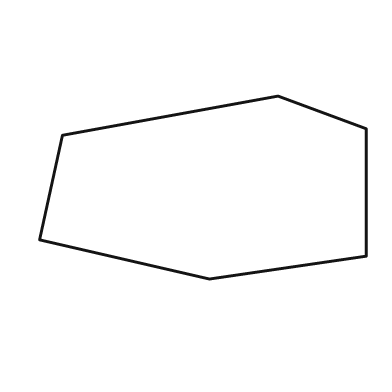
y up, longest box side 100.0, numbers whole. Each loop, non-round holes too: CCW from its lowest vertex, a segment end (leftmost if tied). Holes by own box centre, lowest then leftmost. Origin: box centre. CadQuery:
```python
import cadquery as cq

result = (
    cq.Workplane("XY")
    .moveTo(2.0, -28.0)
    .lineTo(50.0, -21.0)
    .lineTo(50.0, 18.0)
    .lineTo(23.0, 28.0)
    .lineTo(-43.0, 16.0)
    .lineTo(-50.0, -16.0)
    .close()
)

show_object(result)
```